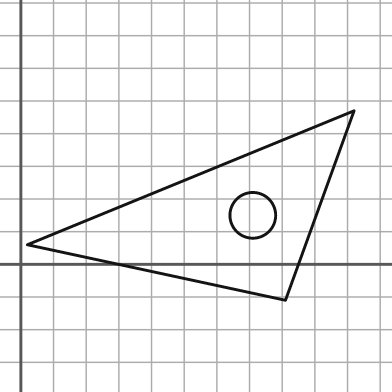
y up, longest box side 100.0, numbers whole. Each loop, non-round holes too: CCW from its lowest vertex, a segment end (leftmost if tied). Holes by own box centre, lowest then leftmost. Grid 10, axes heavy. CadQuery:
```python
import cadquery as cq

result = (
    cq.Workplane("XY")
    .moveTo(81.0, -11.0)
    .lineTo(102.0, 47.0)
    .lineTo(2.0, 6.0)
    .close()
    .moveTo(71.0, 15.0)
    .circle(7.0)
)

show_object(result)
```